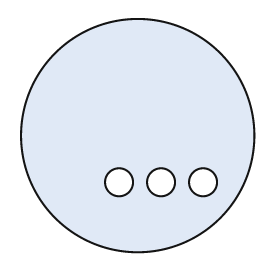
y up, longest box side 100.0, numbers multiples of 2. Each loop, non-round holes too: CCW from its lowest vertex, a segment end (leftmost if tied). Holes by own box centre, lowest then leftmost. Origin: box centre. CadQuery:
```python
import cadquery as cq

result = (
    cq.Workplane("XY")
    .moveTo(0.0, 0.0)
    .circle(50.0)
    .moveTo(-8.0, -20.0)
    .circle(6.0)
    .moveTo(10.0, -20.0)
    .circle(6.0)
    .moveTo(28.0, -20.0)
    .circle(6.0)
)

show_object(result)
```